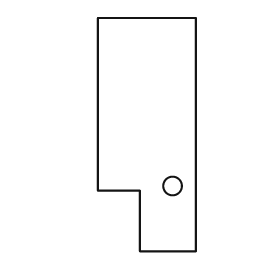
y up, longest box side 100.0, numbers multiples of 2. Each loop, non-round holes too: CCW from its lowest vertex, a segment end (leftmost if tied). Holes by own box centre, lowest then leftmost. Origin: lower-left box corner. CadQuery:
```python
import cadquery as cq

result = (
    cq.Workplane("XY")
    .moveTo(18.0, 0.0)
    .lineTo(42.0, 0.0)
    .lineTo(42.0, 100.0)
    .lineTo(0.0, 100.0)
    .lineTo(0.0, 26.0)
    .lineTo(18.0, 26.0)
    .close()
    .moveTo(32.0, 28.0)
    .circle(4.0)
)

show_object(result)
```